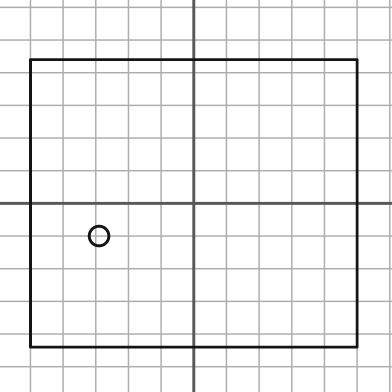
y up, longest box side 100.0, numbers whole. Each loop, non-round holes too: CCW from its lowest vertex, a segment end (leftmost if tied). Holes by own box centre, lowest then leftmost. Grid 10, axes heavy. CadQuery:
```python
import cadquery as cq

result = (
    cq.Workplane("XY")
    .moveTo(-50.0, -44.0)
    .lineTo(50.0, -44.0)
    .lineTo(50.0, 44.0)
    .lineTo(-50.0, 44.0)
    .close()
    .moveTo(-29.0, -10.0)
    .circle(3.0)
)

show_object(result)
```